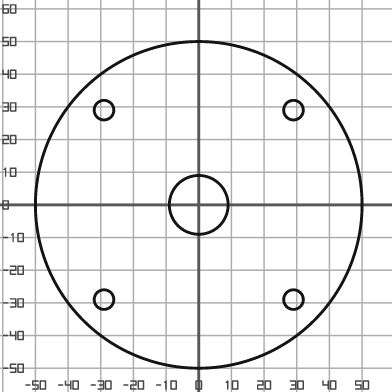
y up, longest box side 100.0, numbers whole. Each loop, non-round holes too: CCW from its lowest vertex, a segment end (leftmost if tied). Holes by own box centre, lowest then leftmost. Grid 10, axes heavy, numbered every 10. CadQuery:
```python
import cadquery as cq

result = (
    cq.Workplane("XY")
    .moveTo(0.0, 0.0)
    .circle(50.0)
    .moveTo(-29.0, -29.0)
    .circle(3.0)
    .moveTo(29.0, -29.0)
    .circle(3.0)
    .moveTo(0.0, 0.0)
    .circle(9.0)
    .moveTo(-29.0, 29.0)
    .circle(3.0)
    .moveTo(29.0, 29.0)
    .circle(3.0)
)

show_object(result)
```